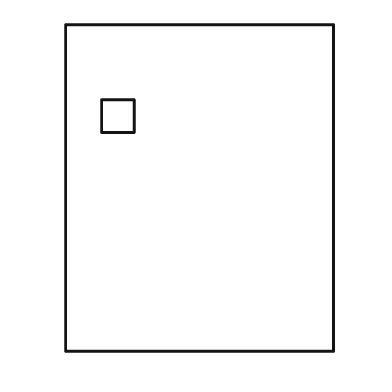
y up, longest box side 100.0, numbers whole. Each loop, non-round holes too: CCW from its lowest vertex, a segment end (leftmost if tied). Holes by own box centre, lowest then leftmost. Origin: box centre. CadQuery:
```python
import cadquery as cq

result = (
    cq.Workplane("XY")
    .moveTo(-41.0, -50.0)
    .lineTo(41.0, -50.0)
    .lineTo(41.0, 50.0)
    .lineTo(-41.0, 50.0)
    .close()
    .moveTo(-30.0, 17.0)
    .lineTo(-20.0, 17.0)
    .lineTo(-20.0, 27.0)
    .lineTo(-30.0, 27.0)
    .close()
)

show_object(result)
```